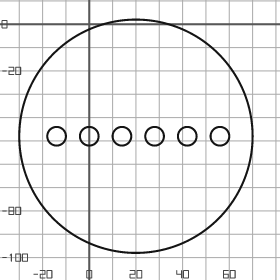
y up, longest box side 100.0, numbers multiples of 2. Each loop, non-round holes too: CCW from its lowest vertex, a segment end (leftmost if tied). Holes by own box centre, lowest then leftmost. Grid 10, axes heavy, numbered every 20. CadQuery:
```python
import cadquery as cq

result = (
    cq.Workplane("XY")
    .moveTo(20.0, -48.0)
    .circle(50.0)
    .moveTo(-14.0, -48.0)
    .circle(4.0)
    .moveTo(0.0, -48.0)
    .circle(4.0)
    .moveTo(14.0, -48.0)
    .circle(4.0)
    .moveTo(28.0, -48.0)
    .circle(4.0)
    .moveTo(42.0, -48.0)
    .circle(4.0)
    .moveTo(56.0, -48.0)
    .circle(4.0)
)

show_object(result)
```